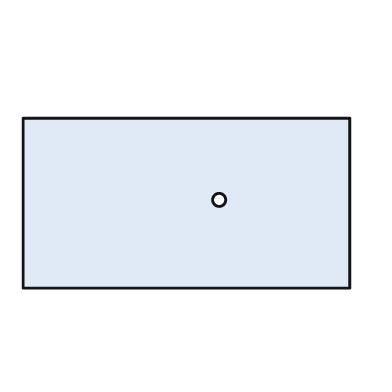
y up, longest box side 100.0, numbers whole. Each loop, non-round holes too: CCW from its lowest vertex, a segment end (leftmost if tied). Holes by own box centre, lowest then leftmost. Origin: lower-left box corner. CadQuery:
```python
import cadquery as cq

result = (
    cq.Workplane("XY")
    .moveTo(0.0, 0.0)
    .lineTo(100.0, 0.0)
    .lineTo(100.0, 52.0)
    .lineTo(0.0, 52.0)
    .close()
    .moveTo(60.0, 27.0)
    .circle(2.0)
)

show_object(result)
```